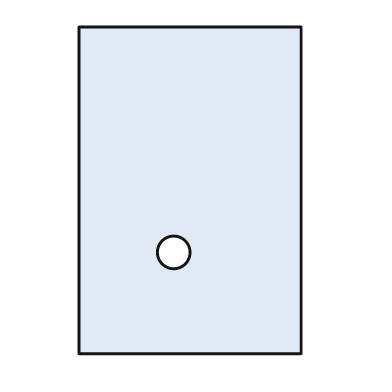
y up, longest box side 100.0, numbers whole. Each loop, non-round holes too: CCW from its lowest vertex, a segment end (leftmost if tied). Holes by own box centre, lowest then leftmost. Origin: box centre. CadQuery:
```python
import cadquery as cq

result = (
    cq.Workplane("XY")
    .moveTo(-34.0, -50.0)
    .lineTo(34.0, -50.0)
    .lineTo(34.0, 50.0)
    .lineTo(-34.0, 50.0)
    .close()
    .moveTo(-5.0, -19.0)
    .circle(5.0)
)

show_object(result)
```